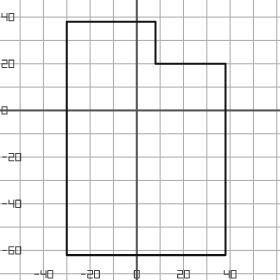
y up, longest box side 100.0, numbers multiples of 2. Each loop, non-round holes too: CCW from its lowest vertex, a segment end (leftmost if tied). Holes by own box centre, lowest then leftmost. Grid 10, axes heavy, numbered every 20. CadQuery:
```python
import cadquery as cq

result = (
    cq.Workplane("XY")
    .moveTo(-30.0, -62.0)
    .lineTo(38.0, -62.0)
    .lineTo(38.0, 20.0)
    .lineTo(8.0, 20.0)
    .lineTo(8.0, 38.0)
    .lineTo(-30.0, 38.0)
    .close()
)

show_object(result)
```